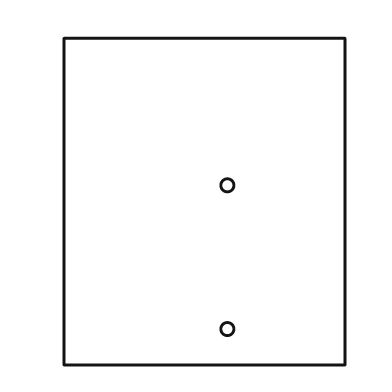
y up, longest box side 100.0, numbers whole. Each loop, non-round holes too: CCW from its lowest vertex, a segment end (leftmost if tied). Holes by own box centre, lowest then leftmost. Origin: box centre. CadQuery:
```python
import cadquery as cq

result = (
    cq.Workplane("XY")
    .moveTo(-43.0, -50.0)
    .lineTo(43.0, -50.0)
    .lineTo(43.0, 50.0)
    .lineTo(-43.0, 50.0)
    .close()
    .moveTo(7.0, -39.0)
    .circle(2.0)
    .moveTo(7.0, 5.0)
    .circle(2.0)
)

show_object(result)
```